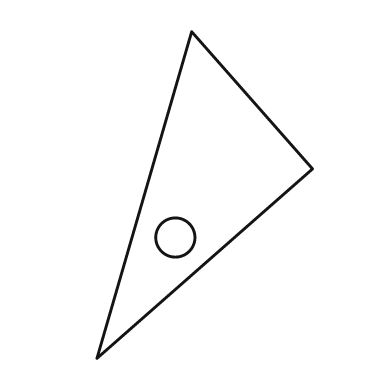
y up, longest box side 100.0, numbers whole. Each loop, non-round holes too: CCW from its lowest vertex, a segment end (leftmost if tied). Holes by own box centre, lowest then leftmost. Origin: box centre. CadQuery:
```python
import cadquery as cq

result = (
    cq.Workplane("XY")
    .moveTo(-33.0, -50.0)
    .lineTo(33.0, 8.0)
    .lineTo(-4.0, 50.0)
    .close()
    .moveTo(-9.0, -13.0)
    .circle(6.0)
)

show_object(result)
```